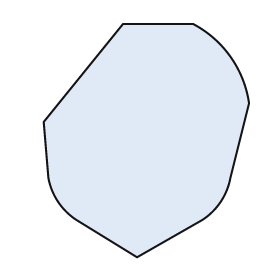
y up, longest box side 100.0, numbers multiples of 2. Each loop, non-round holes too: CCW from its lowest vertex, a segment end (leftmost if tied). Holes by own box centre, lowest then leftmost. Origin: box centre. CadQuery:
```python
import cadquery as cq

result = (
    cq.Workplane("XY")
    .moveTo(-4.0, -50.0)
    .lineTo(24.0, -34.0)
    .threePointArc((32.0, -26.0), (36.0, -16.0))
    .lineTo(44.0, 16.0)
    .threePointArc((36.0, 36.0), (20.0, 50.0))
    .lineTo(-10.0, 50.0)
    .lineTo(-44.0, 8.0)
    .lineTo(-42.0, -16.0)
    .threePointArc((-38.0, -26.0), (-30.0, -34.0))
    .close()
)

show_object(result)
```